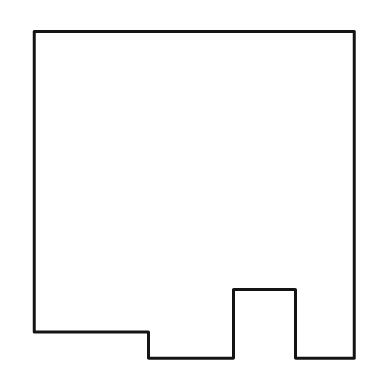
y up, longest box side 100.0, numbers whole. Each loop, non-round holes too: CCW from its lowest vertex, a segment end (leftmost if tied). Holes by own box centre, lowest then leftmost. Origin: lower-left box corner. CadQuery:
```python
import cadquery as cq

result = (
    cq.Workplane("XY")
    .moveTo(35.0, 0.0)
    .lineTo(61.0, 0.0)
    .lineTo(61.0, 21.0)
    .lineTo(80.0, 21.0)
    .lineTo(80.0, 0.0)
    .lineTo(98.0, 0.0)
    .lineTo(98.0, 100.0)
    .lineTo(0.0, 100.0)
    .lineTo(0.0, 8.0)
    .lineTo(35.0, 8.0)
    .close()
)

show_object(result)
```